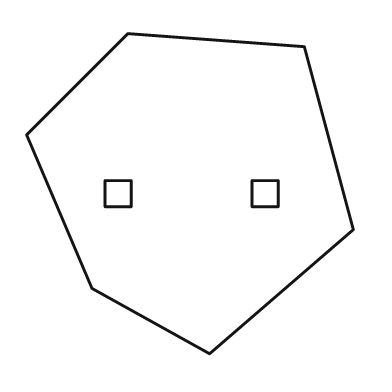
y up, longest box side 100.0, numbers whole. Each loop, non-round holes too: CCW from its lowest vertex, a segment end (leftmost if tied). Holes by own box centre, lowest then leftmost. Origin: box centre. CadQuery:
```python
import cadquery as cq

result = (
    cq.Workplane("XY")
    .moveTo(6.0, -49.0)
    .lineTo(50.0, -11.0)
    .lineTo(35.0, 45.0)
    .lineTo(-19.0, 49.0)
    .lineTo(-50.0, 18.0)
    .lineTo(-30.0, -29.0)
    .close()
    .moveTo(-26.0, -4.0)
    .lineTo(-18.0, -4.0)
    .lineTo(-18.0, 4.0)
    .lineTo(-26.0, 4.0)
    .close()
    .moveTo(19.0, -4.0)
    .lineTo(27.0, -4.0)
    .lineTo(27.0, 4.0)
    .lineTo(19.0, 4.0)
    .close()
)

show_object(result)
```